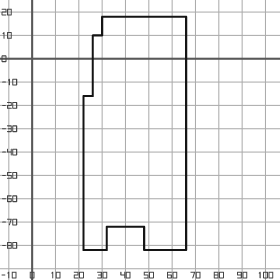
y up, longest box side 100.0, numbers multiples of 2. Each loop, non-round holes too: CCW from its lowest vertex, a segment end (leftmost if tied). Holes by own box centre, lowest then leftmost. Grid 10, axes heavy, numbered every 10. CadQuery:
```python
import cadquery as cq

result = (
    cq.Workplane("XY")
    .moveTo(22.0, -82.0)
    .lineTo(32.0, -82.0)
    .lineTo(32.0, -72.0)
    .lineTo(48.0, -72.0)
    .lineTo(48.0, -82.0)
    .lineTo(66.0, -82.0)
    .lineTo(66.0, 18.0)
    .lineTo(30.0, 18.0)
    .lineTo(30.0, 10.0)
    .lineTo(26.0, 10.0)
    .lineTo(26.0, -16.0)
    .lineTo(22.0, -16.0)
    .close()
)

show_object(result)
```